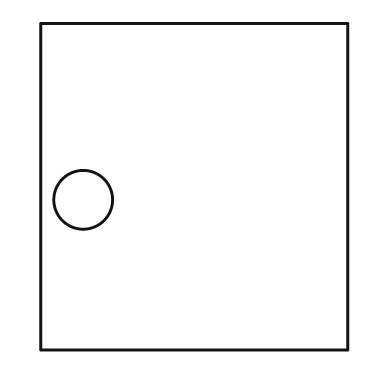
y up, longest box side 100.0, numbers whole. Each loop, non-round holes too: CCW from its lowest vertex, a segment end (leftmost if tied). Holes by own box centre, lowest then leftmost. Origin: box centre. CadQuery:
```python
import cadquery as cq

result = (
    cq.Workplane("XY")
    .moveTo(-47.0, -50.0)
    .lineTo(47.0, -50.0)
    .lineTo(47.0, 50.0)
    .lineTo(-47.0, 50.0)
    .close()
    .moveTo(-34.0, -4.0)
    .circle(9.0)
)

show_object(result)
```